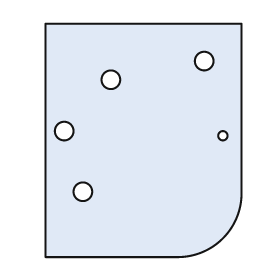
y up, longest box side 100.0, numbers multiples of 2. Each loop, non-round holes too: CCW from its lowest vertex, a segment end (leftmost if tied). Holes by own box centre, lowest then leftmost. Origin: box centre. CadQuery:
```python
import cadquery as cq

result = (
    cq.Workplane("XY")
    .moveTo(-42.0, -50.0)
    .lineTo(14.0, -50.0)
    .threePointArc((34.0, -42.0), (42.0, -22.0))
    .lineTo(42.0, 50.0)
    .lineTo(-42.0, 50.0)
    .close()
    .moveTo(-26.0, -22.0)
    .circle(4.0)
    .moveTo(34.0, 2.0)
    .circle(2.0)
    .moveTo(-34.0, 4.0)
    .circle(4.0)
    .moveTo(-14.0, 26.0)
    .circle(4.0)
    .moveTo(26.0, 34.0)
    .circle(4.0)
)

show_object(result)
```